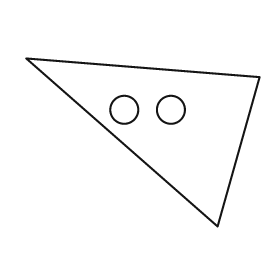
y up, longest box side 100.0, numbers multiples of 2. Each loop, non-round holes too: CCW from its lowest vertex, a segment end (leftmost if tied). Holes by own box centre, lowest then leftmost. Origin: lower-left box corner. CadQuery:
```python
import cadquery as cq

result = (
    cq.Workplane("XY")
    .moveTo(82.0, 0.0)
    .lineTo(100.0, 64.0)
    .lineTo(0.0, 72.0)
    .close()
    .moveTo(42.0, 50.0)
    .circle(6.0)
    .moveTo(62.0, 50.0)
    .circle(6.0)
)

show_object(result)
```